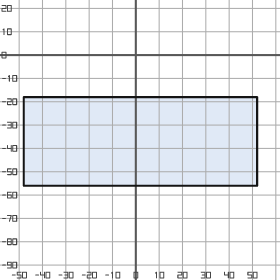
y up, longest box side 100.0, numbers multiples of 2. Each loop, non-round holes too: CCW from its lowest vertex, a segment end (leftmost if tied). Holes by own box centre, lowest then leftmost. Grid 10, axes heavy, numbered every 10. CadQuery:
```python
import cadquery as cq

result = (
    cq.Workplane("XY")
    .moveTo(-48.0, -56.0)
    .lineTo(52.0, -56.0)
    .lineTo(52.0, -18.0)
    .lineTo(-48.0, -18.0)
    .close()
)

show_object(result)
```